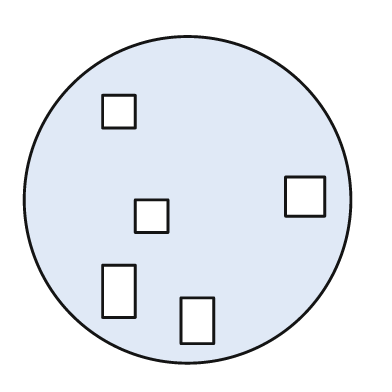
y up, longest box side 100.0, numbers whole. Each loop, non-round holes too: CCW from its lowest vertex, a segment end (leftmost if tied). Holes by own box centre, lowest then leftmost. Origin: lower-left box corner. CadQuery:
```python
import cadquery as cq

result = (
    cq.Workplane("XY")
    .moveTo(50.0, 50.0)
    .circle(50.0)
    .moveTo(48.0, 6.0)
    .lineTo(58.0, 6.0)
    .lineTo(58.0, 20.0)
    .lineTo(48.0, 20.0)
    .close()
    .moveTo(24.0, 14.0)
    .lineTo(34.0, 14.0)
    .lineTo(34.0, 30.0)
    .lineTo(24.0, 30.0)
    .close()
    .moveTo(34.0, 40.0)
    .lineTo(44.0, 40.0)
    .lineTo(44.0, 50.0)
    .lineTo(34.0, 50.0)
    .close()
    .moveTo(80.0, 45.0)
    .lineTo(92.0, 45.0)
    .lineTo(92.0, 57.0)
    .lineTo(80.0, 57.0)
    .close()
    .moveTo(24.0, 72.0)
    .lineTo(34.0, 72.0)
    .lineTo(34.0, 82.0)
    .lineTo(24.0, 82.0)
    .close()
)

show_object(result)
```